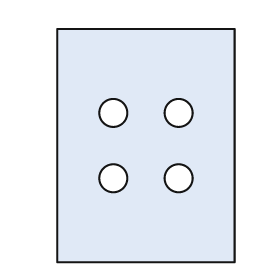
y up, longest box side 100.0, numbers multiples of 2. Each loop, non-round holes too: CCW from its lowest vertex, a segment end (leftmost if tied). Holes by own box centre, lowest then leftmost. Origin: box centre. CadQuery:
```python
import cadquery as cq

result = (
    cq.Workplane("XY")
    .moveTo(-38.0, -50.0)
    .lineTo(38.0, -50.0)
    .lineTo(38.0, 50.0)
    .lineTo(-38.0, 50.0)
    .close()
    .moveTo(-14.0, -14.0)
    .circle(6.0)
    .moveTo(14.0, -14.0)
    .circle(6.0)
    .moveTo(-14.0, 14.0)
    .circle(6.0)
    .moveTo(14.0, 14.0)
    .circle(6.0)
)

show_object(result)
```